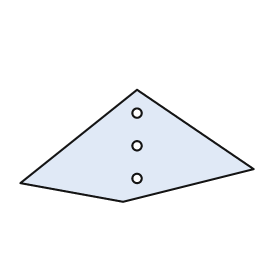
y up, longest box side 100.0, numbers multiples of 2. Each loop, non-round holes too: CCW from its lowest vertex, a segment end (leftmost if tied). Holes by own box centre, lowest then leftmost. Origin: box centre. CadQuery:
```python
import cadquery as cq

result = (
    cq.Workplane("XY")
    .moveTo(-6.0, -24.0)
    .lineTo(50.0, -10.0)
    .lineTo(0.0, 24.0)
    .lineTo(-50.0, -16.0)
    .close()
    .moveTo(0.0, -14.0)
    .circle(2.0)
    .moveTo(0.0, 0.0)
    .circle(2.0)
    .moveTo(0.0, 14.0)
    .circle(2.0)
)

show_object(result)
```